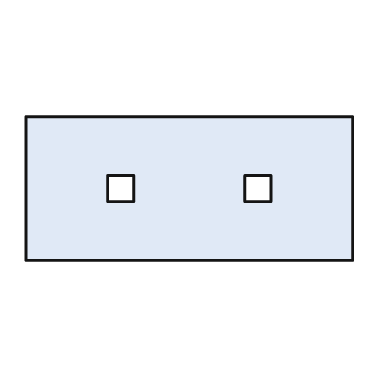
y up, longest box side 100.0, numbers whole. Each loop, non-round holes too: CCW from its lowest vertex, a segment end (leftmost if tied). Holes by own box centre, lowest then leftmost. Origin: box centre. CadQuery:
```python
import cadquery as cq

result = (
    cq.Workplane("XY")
    .moveTo(-50.0, -22.0)
    .lineTo(50.0, -22.0)
    .lineTo(50.0, 22.0)
    .lineTo(-50.0, 22.0)
    .close()
    .moveTo(-25.0, -4.0)
    .lineTo(-17.0, -4.0)
    .lineTo(-17.0, 4.0)
    .lineTo(-25.0, 4.0)
    .close()
    .moveTo(17.0, -4.0)
    .lineTo(25.0, -4.0)
    .lineTo(25.0, 4.0)
    .lineTo(17.0, 4.0)
    .close()
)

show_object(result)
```